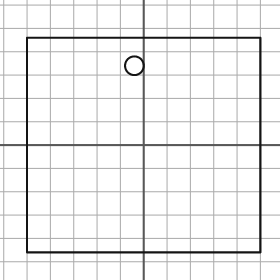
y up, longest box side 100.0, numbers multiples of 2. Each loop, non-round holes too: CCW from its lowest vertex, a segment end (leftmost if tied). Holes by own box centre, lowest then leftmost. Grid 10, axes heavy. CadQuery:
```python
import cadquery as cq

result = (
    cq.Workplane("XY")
    .moveTo(-50.0, -46.0)
    .lineTo(50.0, -46.0)
    .lineTo(50.0, 46.0)
    .lineTo(-50.0, 46.0)
    .close()
    .moveTo(-4.0, 34.0)
    .circle(4.0)
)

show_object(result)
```